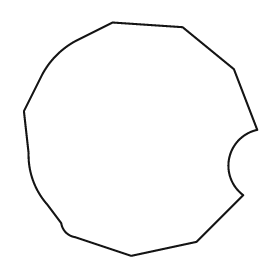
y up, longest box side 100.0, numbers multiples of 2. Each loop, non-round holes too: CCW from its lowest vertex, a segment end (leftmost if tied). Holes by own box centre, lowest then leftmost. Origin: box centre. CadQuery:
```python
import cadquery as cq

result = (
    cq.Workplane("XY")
    .moveTo(-4.0, -50.0)
    .lineTo(24.0, -44.0)
    .lineTo(44.0, -24.0)
    .threePointArc((38.0, -8.0), (50.0, 4.0))
    .lineTo(40.0, 30.0)
    .lineTo(18.0, 48.0)
    .lineTo(-12.0, 50.0)
    .lineTo(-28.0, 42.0)
    .threePointArc((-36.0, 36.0), (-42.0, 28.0))
    .lineTo(-50.0, 12.0)
    .lineTo(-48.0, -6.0)
    .threePointArc((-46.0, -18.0), (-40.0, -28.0))
    .lineTo(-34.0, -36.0)
    .threePointArc((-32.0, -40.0), (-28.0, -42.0))
    .close()
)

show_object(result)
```